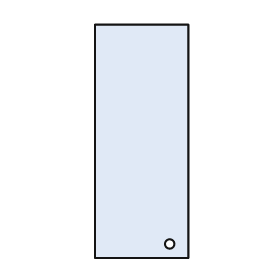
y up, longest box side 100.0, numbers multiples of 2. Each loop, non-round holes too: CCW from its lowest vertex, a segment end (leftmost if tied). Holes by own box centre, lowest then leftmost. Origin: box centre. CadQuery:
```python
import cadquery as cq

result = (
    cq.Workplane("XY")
    .moveTo(-20.0, -50.0)
    .lineTo(20.0, -50.0)
    .lineTo(20.0, 50.0)
    .lineTo(-20.0, 50.0)
    .close()
    .moveTo(12.0, -44.0)
    .circle(2.0)
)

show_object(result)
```